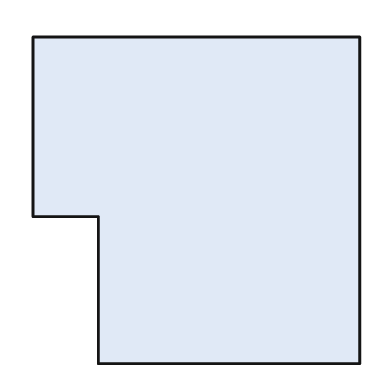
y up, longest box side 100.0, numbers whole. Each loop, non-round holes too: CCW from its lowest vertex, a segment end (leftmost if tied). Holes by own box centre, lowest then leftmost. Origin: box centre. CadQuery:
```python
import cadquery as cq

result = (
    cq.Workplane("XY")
    .moveTo(-30.0, -50.0)
    .lineTo(50.0, -50.0)
    .lineTo(50.0, 50.0)
    .lineTo(-50.0, 50.0)
    .lineTo(-50.0, -5.0)
    .lineTo(-30.0, -5.0)
    .close()
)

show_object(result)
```